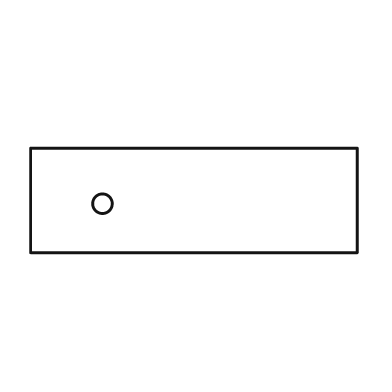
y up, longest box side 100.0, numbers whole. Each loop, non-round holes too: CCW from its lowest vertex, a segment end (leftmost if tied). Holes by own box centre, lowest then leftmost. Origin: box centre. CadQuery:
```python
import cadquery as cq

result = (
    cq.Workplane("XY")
    .moveTo(-50.0, -16.0)
    .lineTo(50.0, -16.0)
    .lineTo(50.0, 16.0)
    .lineTo(-50.0, 16.0)
    .close()
    .moveTo(-28.0, -1.0)
    .circle(3.0)
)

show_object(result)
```